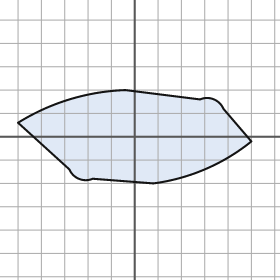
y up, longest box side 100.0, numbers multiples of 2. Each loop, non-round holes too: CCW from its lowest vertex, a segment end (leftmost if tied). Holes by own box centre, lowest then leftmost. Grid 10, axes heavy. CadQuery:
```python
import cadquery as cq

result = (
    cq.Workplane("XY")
    .moveTo(8.0, -20.0)
    .threePointArc((30.0, -14.0), (50.0, -2.0))
    .lineTo(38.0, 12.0)
    .threePointArc((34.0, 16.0), (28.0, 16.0))
    .lineTo(-4.0, 20.0)
    .threePointArc((-28.0, 16.0), (-50.0, 6.0))
    .lineTo(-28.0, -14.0)
    .threePointArc((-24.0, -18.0), (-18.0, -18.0))
    .close()
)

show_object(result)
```